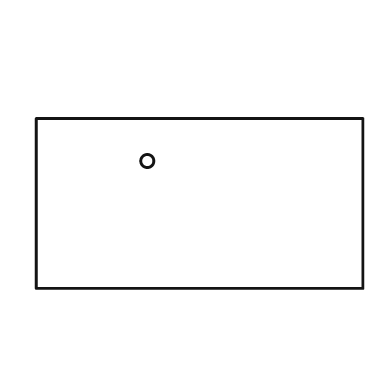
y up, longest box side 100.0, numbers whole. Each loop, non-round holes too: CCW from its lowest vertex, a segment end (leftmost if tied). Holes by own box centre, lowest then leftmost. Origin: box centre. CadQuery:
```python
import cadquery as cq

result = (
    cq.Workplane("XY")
    .moveTo(-50.0, -26.0)
    .lineTo(50.0, -26.0)
    .lineTo(50.0, 26.0)
    .lineTo(-50.0, 26.0)
    .close()
    .moveTo(-16.0, 13.0)
    .circle(2.0)
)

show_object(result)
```